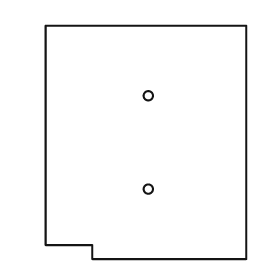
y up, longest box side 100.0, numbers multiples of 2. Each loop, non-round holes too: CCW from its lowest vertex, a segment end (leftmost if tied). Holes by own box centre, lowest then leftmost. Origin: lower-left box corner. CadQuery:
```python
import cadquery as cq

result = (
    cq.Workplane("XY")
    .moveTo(20.0, 0.0)
    .lineTo(86.0, 0.0)
    .lineTo(86.0, 100.0)
    .lineTo(0.0, 100.0)
    .lineTo(0.0, 6.0)
    .lineTo(20.0, 6.0)
    .close()
    .moveTo(44.0, 30.0)
    .circle(2.0)
    .moveTo(44.0, 70.0)
    .circle(2.0)
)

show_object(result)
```